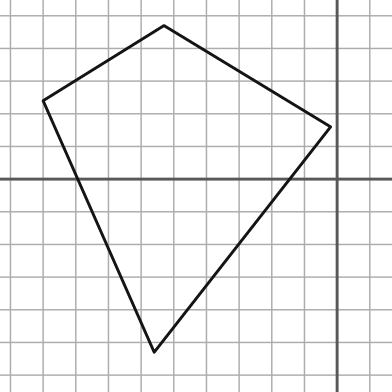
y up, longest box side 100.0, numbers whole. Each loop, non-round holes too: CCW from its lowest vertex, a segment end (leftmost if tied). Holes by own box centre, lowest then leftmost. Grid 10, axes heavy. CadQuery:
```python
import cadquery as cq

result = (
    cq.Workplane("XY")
    .moveTo(-56.0, -53.0)
    .lineTo(-2.0, 16.0)
    .lineTo(-53.0, 47.0)
    .lineTo(-90.0, 24.0)
    .close()
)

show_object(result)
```